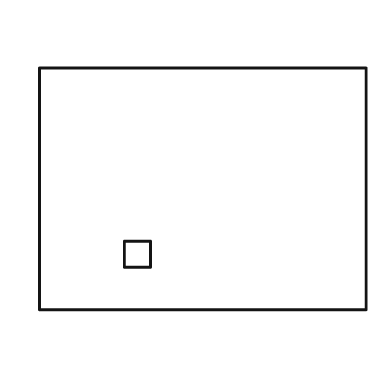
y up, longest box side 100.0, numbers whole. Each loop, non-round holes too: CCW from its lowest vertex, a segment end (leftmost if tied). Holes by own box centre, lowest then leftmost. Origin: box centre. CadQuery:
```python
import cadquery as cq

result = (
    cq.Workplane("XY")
    .moveTo(-50.0, -37.0)
    .lineTo(50.0, -37.0)
    .lineTo(50.0, 37.0)
    .lineTo(-50.0, 37.0)
    .close()
    .moveTo(-24.0, -24.0)
    .lineTo(-16.0, -24.0)
    .lineTo(-16.0, -16.0)
    .lineTo(-24.0, -16.0)
    .close()
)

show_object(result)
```